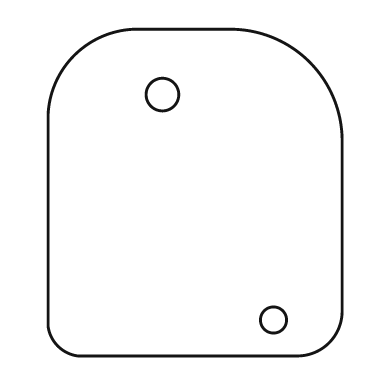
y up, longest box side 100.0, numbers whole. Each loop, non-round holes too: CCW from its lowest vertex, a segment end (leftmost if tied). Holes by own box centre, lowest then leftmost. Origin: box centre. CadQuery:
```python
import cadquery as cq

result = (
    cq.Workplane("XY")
    .moveTo(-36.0, -50.0)
    .lineTo(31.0, -50.0)
    .threePointArc((41.0, -46.0), (45.0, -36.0))
    .lineTo(45.0, 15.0)
    .threePointArc((35.0, 40.0), (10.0, 50.0))
    .lineTo(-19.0, 50.0)
    .threePointArc((-37.0, 42.0), (-45.0, 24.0))
    .lineTo(-45.0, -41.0)
    .threePointArc((-42.0, -47.0), (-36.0, -50.0))
    .close()
    .moveTo(24.0, -39.0)
    .circle(4.0)
    .moveTo(-10.0, 30.0)
    .circle(5.0)
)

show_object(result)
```